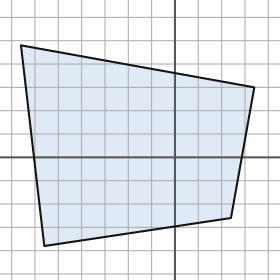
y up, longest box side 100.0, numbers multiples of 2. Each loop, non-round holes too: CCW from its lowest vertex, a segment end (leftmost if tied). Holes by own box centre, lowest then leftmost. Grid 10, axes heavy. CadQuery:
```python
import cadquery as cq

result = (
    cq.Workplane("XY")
    .moveTo(-56.0, -38.0)
    .lineTo(24.0, -26.0)
    .lineTo(34.0, 30.0)
    .lineTo(-66.0, 48.0)
    .close()
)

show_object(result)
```